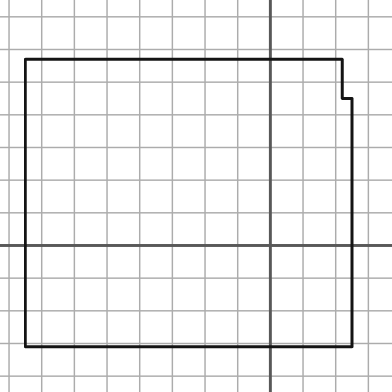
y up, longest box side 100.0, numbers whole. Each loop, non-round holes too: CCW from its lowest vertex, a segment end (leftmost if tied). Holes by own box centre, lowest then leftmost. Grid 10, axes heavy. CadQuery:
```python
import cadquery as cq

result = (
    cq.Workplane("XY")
    .moveTo(-75.0, -31.0)
    .lineTo(25.0, -31.0)
    .lineTo(25.0, 45.0)
    .lineTo(22.0, 45.0)
    .lineTo(22.0, 57.0)
    .lineTo(-75.0, 57.0)
    .close()
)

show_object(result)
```